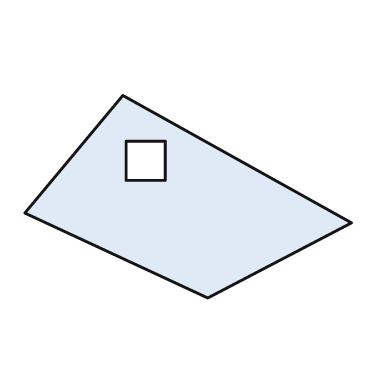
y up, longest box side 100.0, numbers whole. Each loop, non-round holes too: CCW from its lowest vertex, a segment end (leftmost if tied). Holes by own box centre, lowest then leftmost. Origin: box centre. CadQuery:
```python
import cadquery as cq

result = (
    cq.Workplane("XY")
    .moveTo(6.0, -31.0)
    .lineTo(50.0, -8.0)
    .lineTo(-20.0, 31.0)
    .lineTo(-50.0, -5.0)
    .close()
    .moveTo(-19.0, 5.0)
    .lineTo(-7.0, 5.0)
    .lineTo(-7.0, 17.0)
    .lineTo(-19.0, 17.0)
    .close()
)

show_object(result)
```